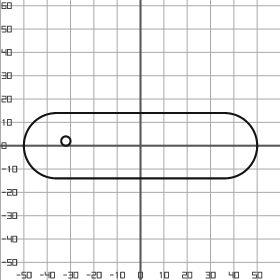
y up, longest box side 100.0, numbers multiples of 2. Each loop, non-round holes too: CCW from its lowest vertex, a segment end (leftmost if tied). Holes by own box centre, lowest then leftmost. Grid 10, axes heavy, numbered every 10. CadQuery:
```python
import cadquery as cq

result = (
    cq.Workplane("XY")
    .moveTo(-36.0, -14.0)
    .lineTo(36.0, -14.0)
    .threePointArc((50.0, 0.0), (36.0, 14.0))
    .lineTo(-36.0, 14.0)
    .threePointArc((-50.0, 0.0), (-36.0, -14.0))
    .close()
    .moveTo(-32.0, 2.0)
    .circle(2.0)
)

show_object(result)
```